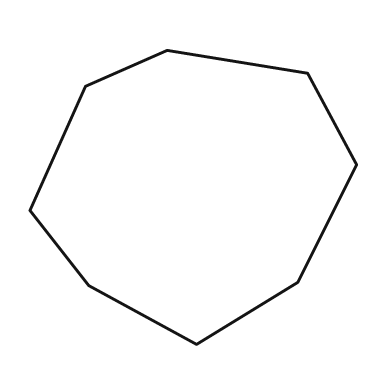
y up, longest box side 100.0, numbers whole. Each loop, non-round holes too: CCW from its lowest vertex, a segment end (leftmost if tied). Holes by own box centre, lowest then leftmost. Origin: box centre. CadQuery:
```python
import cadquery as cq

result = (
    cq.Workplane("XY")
    .moveTo(1.0, -45.0)
    .lineTo(32.0, -26.0)
    .lineTo(50.0, 10.0)
    .lineTo(35.0, 38.0)
    .lineTo(-8.0, 45.0)
    .lineTo(-33.0, 34.0)
    .lineTo(-50.0, -4.0)
    .lineTo(-32.0, -27.0)
    .close()
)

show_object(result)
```